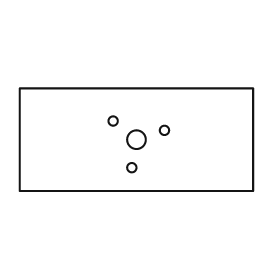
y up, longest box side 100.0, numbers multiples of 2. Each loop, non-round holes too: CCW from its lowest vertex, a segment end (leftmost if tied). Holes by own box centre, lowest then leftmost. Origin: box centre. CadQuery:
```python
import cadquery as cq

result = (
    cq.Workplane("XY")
    .moveTo(-50.0, -22.0)
    .lineTo(50.0, -22.0)
    .lineTo(50.0, 22.0)
    .lineTo(-50.0, 22.0)
    .close()
    .moveTo(-2.0, -12.0)
    .circle(2.0)
    .moveTo(0.0, 0.0)
    .circle(4.0)
    .moveTo(12.0, 4.0)
    .circle(2.0)
    .moveTo(-10.0, 8.0)
    .circle(2.0)
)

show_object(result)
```